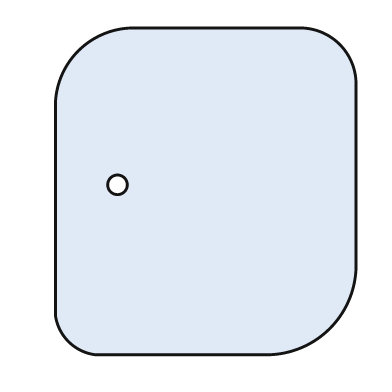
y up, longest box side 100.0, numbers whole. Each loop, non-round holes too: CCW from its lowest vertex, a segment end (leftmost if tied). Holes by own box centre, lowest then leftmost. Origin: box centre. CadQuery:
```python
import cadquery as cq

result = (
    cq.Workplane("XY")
    .moveTo(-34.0, -50.0)
    .lineTo(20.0, -50.0)
    .threePointArc((38.0, -42.0), (46.0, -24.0))
    .lineTo(46.0, 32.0)
    .threePointArc((41.0, 45.0), (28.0, 50.0))
    .lineTo(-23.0, 50.0)
    .threePointArc((-39.0, 43.0), (-46.0, 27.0))
    .lineTo(-46.0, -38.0)
    .threePointArc((-42.0, -46.0), (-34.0, -50.0))
    .close()
    .moveTo(-27.0, 2.0)
    .circle(3.0)
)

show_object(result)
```